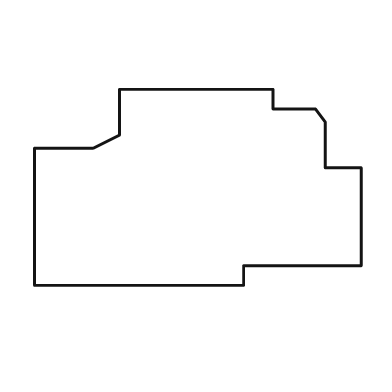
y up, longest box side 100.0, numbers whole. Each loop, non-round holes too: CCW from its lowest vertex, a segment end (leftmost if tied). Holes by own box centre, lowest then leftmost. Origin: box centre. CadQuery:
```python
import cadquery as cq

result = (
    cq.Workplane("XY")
    .moveTo(-50.0, -30.0)
    .lineTo(14.0, -30.0)
    .lineTo(14.0, -24.0)
    .lineTo(50.0, -24.0)
    .lineTo(50.0, 6.0)
    .lineTo(39.0, 6.0)
    .lineTo(39.0, 20.0)
    .lineTo(36.0, 24.0)
    .lineTo(23.0, 24.0)
    .lineTo(23.0, 30.0)
    .lineTo(-24.0, 30.0)
    .lineTo(-24.0, 16.0)
    .lineTo(-32.0, 12.0)
    .lineTo(-50.0, 12.0)
    .close()
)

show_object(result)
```